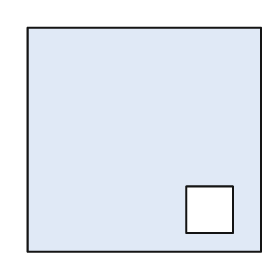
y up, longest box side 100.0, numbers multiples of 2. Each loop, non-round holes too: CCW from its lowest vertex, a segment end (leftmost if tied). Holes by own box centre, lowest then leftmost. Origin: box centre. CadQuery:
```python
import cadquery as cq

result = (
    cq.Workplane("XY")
    .moveTo(-50.0, -48.0)
    .lineTo(50.0, -48.0)
    .lineTo(50.0, 48.0)
    .lineTo(-50.0, 48.0)
    .close()
    .moveTo(18.0, -40.0)
    .lineTo(38.0, -40.0)
    .lineTo(38.0, -20.0)
    .lineTo(18.0, -20.0)
    .close()
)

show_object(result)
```